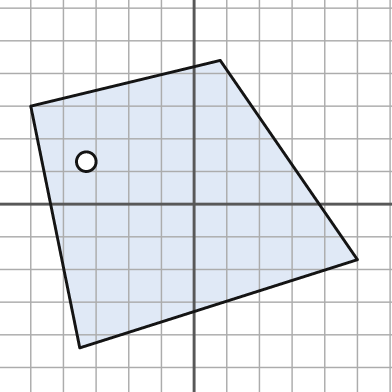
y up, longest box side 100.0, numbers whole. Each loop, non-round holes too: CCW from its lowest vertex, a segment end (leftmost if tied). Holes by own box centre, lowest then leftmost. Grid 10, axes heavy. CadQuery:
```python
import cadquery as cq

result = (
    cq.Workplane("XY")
    .moveTo(-35.0, -44.0)
    .lineTo(50.0, -17.0)
    .lineTo(8.0, 44.0)
    .lineTo(-50.0, 30.0)
    .close()
    .moveTo(-33.0, 13.0)
    .circle(3.0)
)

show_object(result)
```